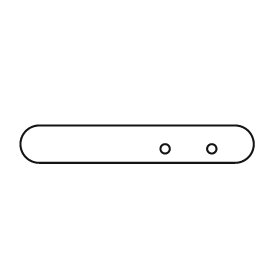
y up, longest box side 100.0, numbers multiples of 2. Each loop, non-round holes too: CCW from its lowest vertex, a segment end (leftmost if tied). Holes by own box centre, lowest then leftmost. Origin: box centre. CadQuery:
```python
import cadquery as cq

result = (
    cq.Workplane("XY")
    .moveTo(-42.0, -8.0)
    .lineTo(42.0, -8.0)
    .threePointArc((50.0, 0.0), (42.0, 8.0))
    .lineTo(-42.0, 8.0)
    .threePointArc((-50.0, 0.0), (-42.0, -8.0))
    .close()
    .moveTo(12.0, -2.0)
    .circle(2.0)
    .moveTo(32.0, -2.0)
    .circle(2.0)
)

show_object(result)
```